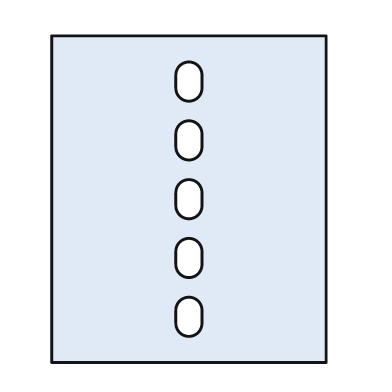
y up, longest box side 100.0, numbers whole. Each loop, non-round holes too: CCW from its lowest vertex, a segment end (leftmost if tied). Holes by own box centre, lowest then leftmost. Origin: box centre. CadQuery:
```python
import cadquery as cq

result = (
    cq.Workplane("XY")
    .moveTo(-42.0, -50.0)
    .lineTo(42.0, -50.0)
    .lineTo(42.0, 50.0)
    .lineTo(-42.0, 50.0)
    .close()
    .moveTo(-4.0, -38.0)
    .threePointArc((0.0, -42.0), (4.0, -38.0))
    .lineTo(4.0, -34.0)
    .threePointArc((0.0, -30.0), (-4.0, -34.0))
    .close()
    .moveTo(-4.0, -20.0)
    .threePointArc((0.0, -24.0), (4.0, -20.0))
    .lineTo(4.0, -16.0)
    .threePointArc((0.0, -12.0), (-4.0, -16.0))
    .close()
    .moveTo(-4.0, -2.0)
    .threePointArc((0.0, -6.0), (4.0, -2.0))
    .lineTo(4.0, 2.0)
    .threePointArc((0.0, 6.0), (-4.0, 2.0))
    .close()
    .moveTo(-4.0, 16.0)
    .threePointArc((0.0, 12.0), (4.0, 16.0))
    .lineTo(4.0, 20.0)
    .threePointArc((0.0, 24.0), (-4.0, 20.0))
    .close()
    .moveTo(-4.0, 34.0)
    .threePointArc((0.0, 30.0), (4.0, 34.0))
    .lineTo(4.0, 38.0)
    .threePointArc((0.0, 42.0), (-4.0, 38.0))
    .close()
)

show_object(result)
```